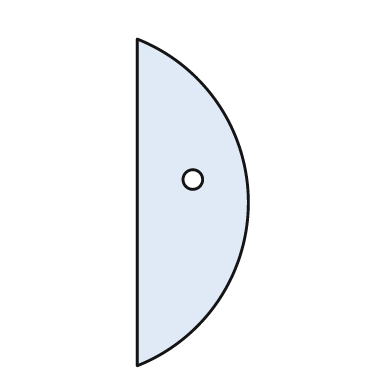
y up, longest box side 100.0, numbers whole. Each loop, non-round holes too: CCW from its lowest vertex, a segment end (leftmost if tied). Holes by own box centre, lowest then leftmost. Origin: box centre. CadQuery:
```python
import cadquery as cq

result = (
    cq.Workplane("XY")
    .moveTo(-17.0, -50.0)
    .threePointArc((17.0, 0.0), (-17.0, 50.0))
    .close()
    .moveTo(0.0, 7.0)
    .circle(3.0)
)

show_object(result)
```